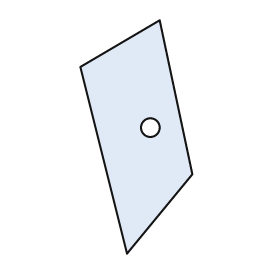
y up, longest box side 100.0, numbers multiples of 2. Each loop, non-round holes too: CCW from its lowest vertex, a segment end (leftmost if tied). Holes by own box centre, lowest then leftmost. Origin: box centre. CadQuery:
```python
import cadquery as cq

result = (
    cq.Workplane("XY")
    .moveTo(-4.0, -50.0)
    .lineTo(24.0, -16.0)
    .lineTo(10.0, 50.0)
    .lineTo(-24.0, 30.0)
    .close()
    .moveTo(6.0, 4.0)
    .circle(4.0)
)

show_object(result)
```